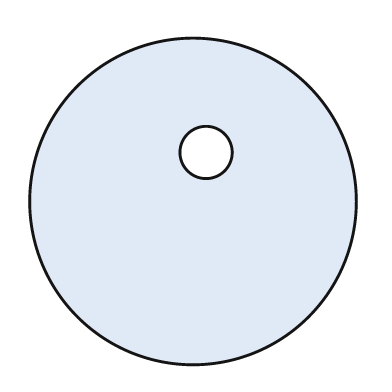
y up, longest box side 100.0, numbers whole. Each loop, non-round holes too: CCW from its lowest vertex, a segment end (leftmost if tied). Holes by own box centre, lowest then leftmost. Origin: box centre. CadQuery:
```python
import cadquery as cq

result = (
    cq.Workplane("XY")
    .moveTo(0.0, 0.0)
    .circle(50.0)
    .moveTo(4.0, 15.0)
    .circle(8.0)
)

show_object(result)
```